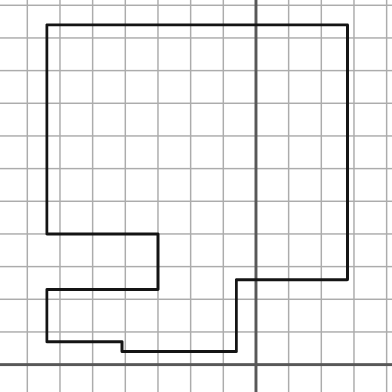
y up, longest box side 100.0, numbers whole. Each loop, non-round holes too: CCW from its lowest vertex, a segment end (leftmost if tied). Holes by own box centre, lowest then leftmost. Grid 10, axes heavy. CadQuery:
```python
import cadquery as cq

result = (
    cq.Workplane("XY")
    .moveTo(-41.0, 4.0)
    .lineTo(-6.0, 4.0)
    .lineTo(-6.0, 26.0)
    .lineTo(28.0, 26.0)
    .lineTo(28.0, 104.0)
    .lineTo(-64.0, 104.0)
    .lineTo(-64.0, 40.0)
    .lineTo(-30.0, 40.0)
    .lineTo(-30.0, 23.0)
    .lineTo(-64.0, 23.0)
    .lineTo(-64.0, 7.0)
    .lineTo(-41.0, 7.0)
    .close()
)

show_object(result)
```